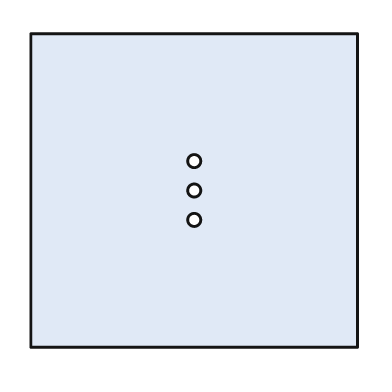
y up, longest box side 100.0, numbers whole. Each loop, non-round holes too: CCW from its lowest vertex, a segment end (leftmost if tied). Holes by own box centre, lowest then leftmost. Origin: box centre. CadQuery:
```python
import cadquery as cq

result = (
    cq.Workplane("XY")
    .moveTo(-50.0, -48.0)
    .lineTo(50.0, -48.0)
    .lineTo(50.0, 48.0)
    .lineTo(-50.0, 48.0)
    .close()
    .moveTo(0.0, -9.0)
    .circle(2.0)
    .moveTo(0.0, 0.0)
    .circle(2.0)
    .moveTo(0.0, 9.0)
    .circle(2.0)
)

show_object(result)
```